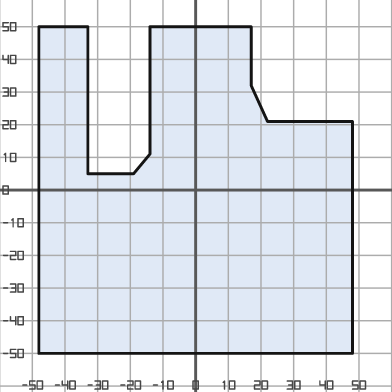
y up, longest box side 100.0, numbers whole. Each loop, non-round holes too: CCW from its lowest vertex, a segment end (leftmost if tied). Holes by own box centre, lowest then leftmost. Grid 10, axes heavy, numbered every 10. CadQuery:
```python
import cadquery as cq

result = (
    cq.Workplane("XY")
    .moveTo(-48.0, -50.0)
    .lineTo(48.0, -50.0)
    .lineTo(48.0, 21.0)
    .lineTo(22.0, 21.0)
    .lineTo(17.0, 32.0)
    .lineTo(17.0, 50.0)
    .lineTo(-14.0, 50.0)
    .lineTo(-14.0, 11.0)
    .lineTo(-19.0, 5.0)
    .lineTo(-33.0, 5.0)
    .lineTo(-33.0, 50.0)
    .lineTo(-48.0, 50.0)
    .close()
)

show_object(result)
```